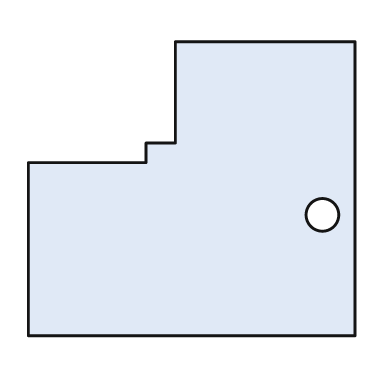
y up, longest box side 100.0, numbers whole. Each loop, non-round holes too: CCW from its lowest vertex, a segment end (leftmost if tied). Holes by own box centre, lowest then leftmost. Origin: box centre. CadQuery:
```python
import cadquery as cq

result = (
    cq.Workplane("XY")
    .moveTo(-50.0, -45.0)
    .lineTo(50.0, -45.0)
    .lineTo(50.0, 45.0)
    .lineTo(-5.0, 45.0)
    .lineTo(-5.0, 14.0)
    .lineTo(-14.0, 14.0)
    .lineTo(-14.0, 8.0)
    .lineTo(-50.0, 8.0)
    .close()
    .moveTo(40.0, -8.0)
    .circle(5.0)
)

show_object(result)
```